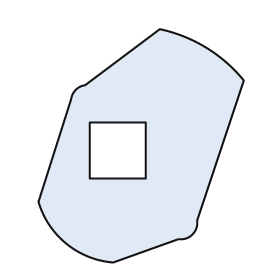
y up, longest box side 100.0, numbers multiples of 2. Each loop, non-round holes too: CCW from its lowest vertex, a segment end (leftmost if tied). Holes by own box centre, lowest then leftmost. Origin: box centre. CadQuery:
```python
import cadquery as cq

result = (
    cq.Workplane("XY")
    .moveTo(-12.0, -50.0)
    .lineTo(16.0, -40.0)
    .threePointArc((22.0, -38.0), (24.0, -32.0))
    .lineTo(44.0, 28.0)
    .threePointArc((28.0, 42.0), (8.0, 50.0))
    .lineTo(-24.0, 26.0)
    .threePointArc((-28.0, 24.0), (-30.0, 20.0))
    .lineTo(-44.0, -24.0)
    .threePointArc((-32.0, -42.0), (-12.0, -50.0))
    .close()
    .moveTo(-22.0, -14.0)
    .lineTo(2.0, -14.0)
    .lineTo(2.0, 10.0)
    .lineTo(-22.0, 10.0)
    .close()
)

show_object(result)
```